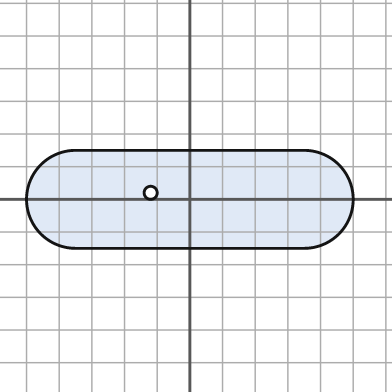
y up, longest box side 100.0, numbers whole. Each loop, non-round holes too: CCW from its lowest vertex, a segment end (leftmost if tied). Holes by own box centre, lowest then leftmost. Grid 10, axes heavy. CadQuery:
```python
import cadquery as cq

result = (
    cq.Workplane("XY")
    .moveTo(-35.0, -15.0)
    .lineTo(35.0, -15.0)
    .threePointArc((50.0, 0.0), (35.0, 15.0))
    .lineTo(-35.0, 15.0)
    .threePointArc((-50.0, 0.0), (-35.0, -15.0))
    .close()
    .moveTo(-12.0, 2.0)
    .circle(2.0)
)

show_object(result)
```